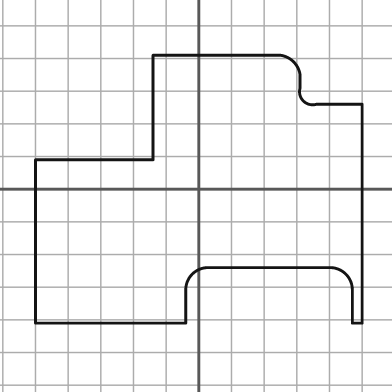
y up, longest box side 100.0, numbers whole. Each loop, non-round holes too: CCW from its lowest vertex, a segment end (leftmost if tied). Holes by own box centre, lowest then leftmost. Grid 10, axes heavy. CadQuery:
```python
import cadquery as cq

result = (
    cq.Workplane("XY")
    .moveTo(-50.0, -41.0)
    .lineTo(-4.0, -41.0)
    .lineTo(-4.0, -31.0)
    .threePointArc((-2.0, -26.0), (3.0, -24.0))
    .lineTo(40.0, -24.0)
    .threePointArc((45.0, -26.0), (47.0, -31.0))
    .lineTo(47.0, -41.0)
    .lineTo(50.0, -41.0)
    .lineTo(50.0, 26.0)
    .lineTo(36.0, 26.0)
    .threePointArc((32.0, 27.0), (31.0, 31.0))
    .lineTo(31.0, 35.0)
    .threePointArc((29.0, 39.0), (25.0, 41.0))
    .lineTo(-14.0, 41.0)
    .lineTo(-14.0, 9.0)
    .lineTo(-50.0, 9.0)
    .close()
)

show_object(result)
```